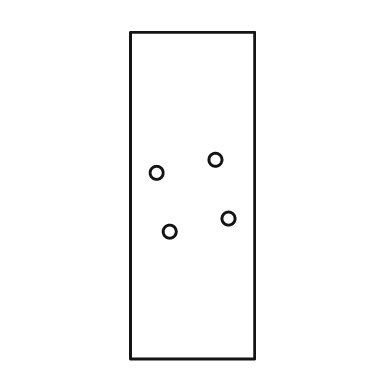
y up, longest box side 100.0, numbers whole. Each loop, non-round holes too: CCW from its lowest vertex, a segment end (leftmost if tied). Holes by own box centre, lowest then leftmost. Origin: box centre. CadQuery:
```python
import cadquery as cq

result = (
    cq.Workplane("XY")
    .moveTo(-19.0, -50.0)
    .lineTo(19.0, -50.0)
    .lineTo(19.0, 50.0)
    .lineTo(-19.0, 50.0)
    .close()
    .moveTo(-7.0, -11.0)
    .circle(2.0)
    .moveTo(11.0, -7.0)
    .circle(2.0)
    .moveTo(-11.0, 7.0)
    .circle(2.0)
    .moveTo(7.0, 11.0)
    .circle(2.0)
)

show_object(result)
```